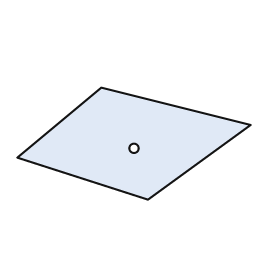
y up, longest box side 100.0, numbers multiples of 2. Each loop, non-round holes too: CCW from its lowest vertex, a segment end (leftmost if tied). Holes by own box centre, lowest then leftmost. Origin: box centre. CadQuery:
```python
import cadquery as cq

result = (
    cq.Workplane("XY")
    .moveTo(6.0, -24.0)
    .lineTo(50.0, 8.0)
    .lineTo(-14.0, 24.0)
    .lineTo(-50.0, -6.0)
    .close()
    .moveTo(0.0, -2.0)
    .circle(2.0)
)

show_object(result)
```